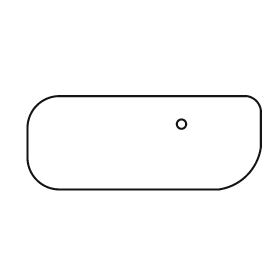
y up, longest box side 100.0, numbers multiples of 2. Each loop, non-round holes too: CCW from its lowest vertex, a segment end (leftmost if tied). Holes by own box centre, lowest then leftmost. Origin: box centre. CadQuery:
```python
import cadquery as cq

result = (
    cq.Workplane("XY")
    .moveTo(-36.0, -20.0)
    .lineTo(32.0, -20.0)
    .threePointArc((44.0, -14.0), (50.0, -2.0))
    .lineTo(50.0, 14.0)
    .threePointArc((48.0, 18.0), (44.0, 20.0))
    .lineTo(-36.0, 20.0)
    .threePointArc((-46.0, 16.0), (-50.0, 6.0))
    .lineTo(-50.0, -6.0)
    .threePointArc((-46.0, -16.0), (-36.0, -20.0))
    .close()
    .moveTo(16.0, 8.0)
    .circle(2.0)
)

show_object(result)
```